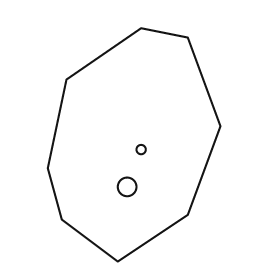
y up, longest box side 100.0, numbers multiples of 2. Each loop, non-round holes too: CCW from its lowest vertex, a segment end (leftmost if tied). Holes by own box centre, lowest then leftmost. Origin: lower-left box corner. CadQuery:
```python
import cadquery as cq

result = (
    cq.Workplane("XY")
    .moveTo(30.0, 0.0)
    .lineTo(60.0, 20.0)
    .lineTo(74.0, 58.0)
    .lineTo(60.0, 96.0)
    .lineTo(40.0, 100.0)
    .lineTo(8.0, 78.0)
    .lineTo(0.0, 40.0)
    .lineTo(6.0, 18.0)
    .close()
    .moveTo(34.0, 32.0)
    .circle(4.0)
    .moveTo(40.0, 48.0)
    .circle(2.0)
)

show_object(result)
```